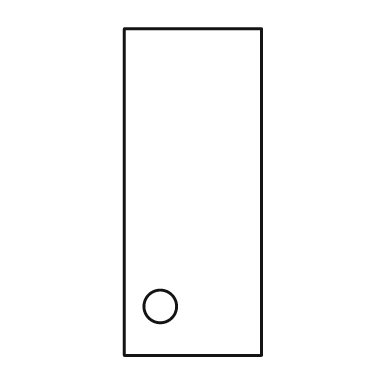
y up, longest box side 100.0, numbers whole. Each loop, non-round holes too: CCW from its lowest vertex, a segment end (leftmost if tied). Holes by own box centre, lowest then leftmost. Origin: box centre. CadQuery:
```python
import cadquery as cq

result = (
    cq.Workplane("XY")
    .moveTo(-21.0, -50.0)
    .lineTo(21.0, -50.0)
    .lineTo(21.0, 50.0)
    .lineTo(-21.0, 50.0)
    .close()
    .moveTo(-10.0, -35.0)
    .circle(5.0)
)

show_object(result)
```